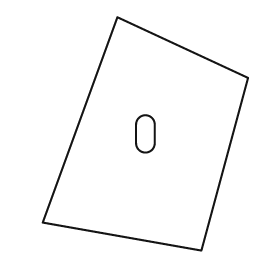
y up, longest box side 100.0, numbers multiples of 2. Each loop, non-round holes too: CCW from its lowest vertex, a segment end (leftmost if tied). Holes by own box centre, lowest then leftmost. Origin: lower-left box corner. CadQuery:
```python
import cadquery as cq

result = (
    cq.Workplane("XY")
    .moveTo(68.0, 0.0)
    .lineTo(88.0, 74.0)
    .lineTo(32.0, 100.0)
    .lineTo(0.0, 12.0)
    .close()
    .moveTo(40.0, 46.0)
    .threePointArc((44.0, 42.0), (48.0, 46.0))
    .lineTo(48.0, 54.0)
    .threePointArc((44.0, 58.0), (40.0, 54.0))
    .close()
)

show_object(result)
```